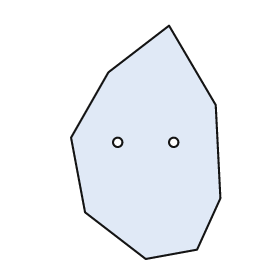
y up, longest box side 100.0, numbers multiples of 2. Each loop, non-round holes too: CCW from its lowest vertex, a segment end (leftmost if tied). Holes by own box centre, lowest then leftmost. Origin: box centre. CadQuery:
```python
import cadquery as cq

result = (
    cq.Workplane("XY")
    .moveTo(0.0, -50.0)
    .lineTo(22.0, -46.0)
    .lineTo(32.0, -24.0)
    .lineTo(30.0, 16.0)
    .lineTo(10.0, 50.0)
    .lineTo(-16.0, 30.0)
    .lineTo(-32.0, 2.0)
    .lineTo(-26.0, -30.0)
    .close()
    .moveTo(-12.0, 0.0)
    .circle(2.0)
    .moveTo(12.0, 0.0)
    .circle(2.0)
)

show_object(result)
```